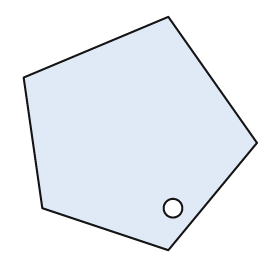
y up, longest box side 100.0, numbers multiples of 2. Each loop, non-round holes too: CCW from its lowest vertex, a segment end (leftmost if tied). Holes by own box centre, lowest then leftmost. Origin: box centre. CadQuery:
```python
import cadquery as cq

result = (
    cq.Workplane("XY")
    .moveTo(12.0, -50.0)
    .lineTo(50.0, -4.0)
    .lineTo(12.0, 50.0)
    .lineTo(-50.0, 24.0)
    .lineTo(-42.0, -32.0)
    .close()
    .moveTo(14.0, -32.0)
    .circle(4.0)
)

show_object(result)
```